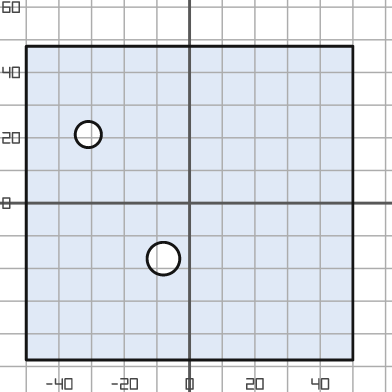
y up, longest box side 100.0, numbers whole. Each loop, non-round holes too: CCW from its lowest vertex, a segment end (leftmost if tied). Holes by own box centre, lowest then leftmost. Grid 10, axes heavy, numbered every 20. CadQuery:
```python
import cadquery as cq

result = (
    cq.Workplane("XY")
    .moveTo(-50.0, -48.0)
    .lineTo(50.0, -48.0)
    .lineTo(50.0, 48.0)
    .lineTo(-50.0, 48.0)
    .close()
    .moveTo(-8.0, -17.0)
    .circle(5.0)
    .moveTo(-31.0, 21.0)
    .circle(4.0)
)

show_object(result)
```